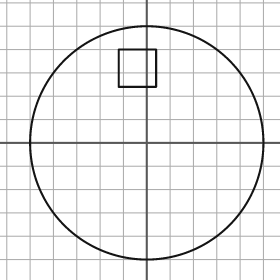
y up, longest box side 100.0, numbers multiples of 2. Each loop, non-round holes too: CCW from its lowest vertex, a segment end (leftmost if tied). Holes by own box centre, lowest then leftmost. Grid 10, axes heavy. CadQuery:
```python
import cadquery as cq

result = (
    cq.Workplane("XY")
    .moveTo(0.0, 0.0)
    .circle(50.0)
    .moveTo(-12.0, 24.0)
    .lineTo(4.0, 24.0)
    .lineTo(4.0, 40.0)
    .lineTo(-12.0, 40.0)
    .close()
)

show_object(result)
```